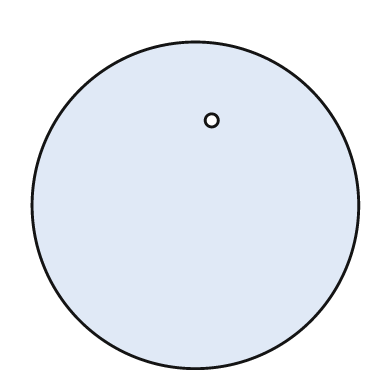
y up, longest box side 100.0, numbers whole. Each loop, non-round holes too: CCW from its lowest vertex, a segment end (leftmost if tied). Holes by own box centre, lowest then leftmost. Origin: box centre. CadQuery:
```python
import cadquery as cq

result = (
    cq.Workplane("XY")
    .moveTo(0.0, 0.0)
    .circle(50.0)
    .moveTo(5.0, 26.0)
    .circle(2.0)
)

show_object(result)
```